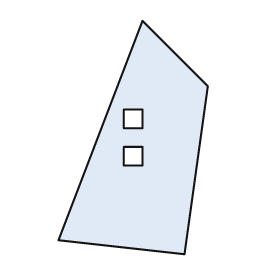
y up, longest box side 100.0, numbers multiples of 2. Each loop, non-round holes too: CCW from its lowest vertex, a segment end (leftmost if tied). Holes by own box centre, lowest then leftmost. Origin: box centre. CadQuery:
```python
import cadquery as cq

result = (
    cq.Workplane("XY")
    .moveTo(22.0, -50.0)
    .lineTo(32.0, 22.0)
    .lineTo(4.0, 50.0)
    .lineTo(-32.0, -44.0)
    .close()
    .moveTo(-4.0, -12.0)
    .lineTo(4.0, -12.0)
    .lineTo(4.0, -4.0)
    .lineTo(-4.0, -4.0)
    .close()
    .moveTo(-4.0, 4.0)
    .lineTo(4.0, 4.0)
    .lineTo(4.0, 12.0)
    .lineTo(-4.0, 12.0)
    .close()
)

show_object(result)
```